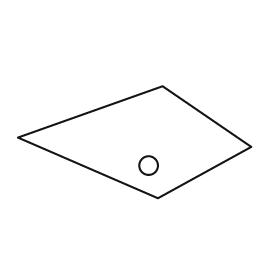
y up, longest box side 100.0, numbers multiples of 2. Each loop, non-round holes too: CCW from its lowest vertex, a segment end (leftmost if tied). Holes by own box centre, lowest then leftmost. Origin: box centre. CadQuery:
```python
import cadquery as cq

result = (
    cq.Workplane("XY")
    .moveTo(10.0, -24.0)
    .lineTo(50.0, -2.0)
    .lineTo(12.0, 24.0)
    .lineTo(-50.0, 2.0)
    .close()
    .moveTo(6.0, -10.0)
    .circle(4.0)
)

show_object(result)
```